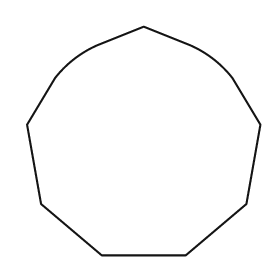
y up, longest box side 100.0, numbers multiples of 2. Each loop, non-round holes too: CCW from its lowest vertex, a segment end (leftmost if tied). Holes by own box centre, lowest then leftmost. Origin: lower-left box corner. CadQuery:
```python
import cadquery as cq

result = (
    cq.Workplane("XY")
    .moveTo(32.0, 0.0)
    .lineTo(68.0, 0.0)
    .lineTo(94.0, 22.0)
    .lineTo(100.0, 56.0)
    .lineTo(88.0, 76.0)
    .threePointArc((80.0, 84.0), (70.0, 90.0))
    .lineTo(50.0, 98.0)
    .lineTo(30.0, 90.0)
    .threePointArc((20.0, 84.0), (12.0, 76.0))
    .lineTo(0.0, 56.0)
    .lineTo(6.0, 22.0)
    .close()
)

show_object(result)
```